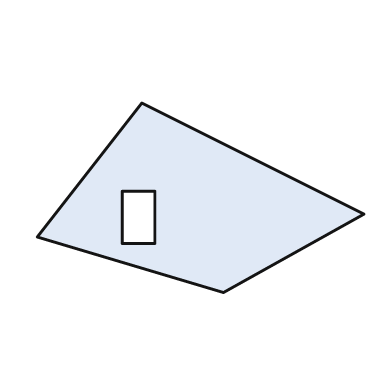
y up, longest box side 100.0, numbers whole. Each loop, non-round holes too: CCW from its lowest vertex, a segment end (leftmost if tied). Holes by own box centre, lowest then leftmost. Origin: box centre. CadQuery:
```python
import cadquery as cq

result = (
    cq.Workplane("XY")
    .moveTo(7.0, -29.0)
    .lineTo(50.0, -5.0)
    .lineTo(-18.0, 29.0)
    .lineTo(-50.0, -12.0)
    .close()
    .moveTo(-24.0, -14.0)
    .lineTo(-14.0, -14.0)
    .lineTo(-14.0, 2.0)
    .lineTo(-24.0, 2.0)
    .close()
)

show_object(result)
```